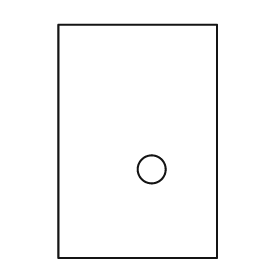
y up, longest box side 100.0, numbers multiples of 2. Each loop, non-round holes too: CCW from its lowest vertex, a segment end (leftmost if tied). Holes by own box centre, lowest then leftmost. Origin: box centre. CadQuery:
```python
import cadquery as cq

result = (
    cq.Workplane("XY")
    .moveTo(-34.0, -50.0)
    .lineTo(34.0, -50.0)
    .lineTo(34.0, 50.0)
    .lineTo(-34.0, 50.0)
    .close()
    .moveTo(6.0, -12.0)
    .circle(6.0)
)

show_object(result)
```